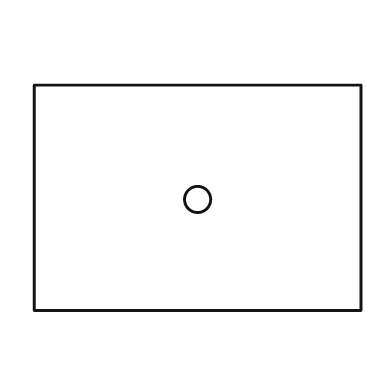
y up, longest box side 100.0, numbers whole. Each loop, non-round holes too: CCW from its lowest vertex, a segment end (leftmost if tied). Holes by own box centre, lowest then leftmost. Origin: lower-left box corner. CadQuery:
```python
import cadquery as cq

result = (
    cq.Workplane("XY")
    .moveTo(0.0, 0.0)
    .lineTo(100.0, 0.0)
    .lineTo(100.0, 69.0)
    .lineTo(0.0, 69.0)
    .close()
    .moveTo(50.0, 34.0)
    .circle(4.0)
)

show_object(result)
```